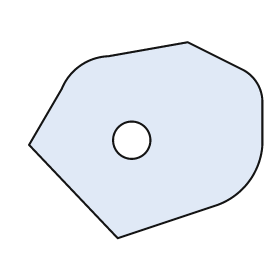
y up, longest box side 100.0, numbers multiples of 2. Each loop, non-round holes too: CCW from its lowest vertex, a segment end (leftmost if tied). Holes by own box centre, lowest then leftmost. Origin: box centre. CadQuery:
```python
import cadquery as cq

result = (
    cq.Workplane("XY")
    .moveTo(-12.0, -42.0)
    .lineTo(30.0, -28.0)
    .threePointArc((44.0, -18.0), (50.0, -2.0))
    .lineTo(50.0, 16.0)
    .threePointArc((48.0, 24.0), (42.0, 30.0))
    .lineTo(18.0, 42.0)
    .lineTo(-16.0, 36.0)
    .threePointArc((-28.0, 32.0), (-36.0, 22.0))
    .lineTo(-50.0, -2.0)
    .close()
    .moveTo(-6.0, 0.0)
    .circle(8.0)
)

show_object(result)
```